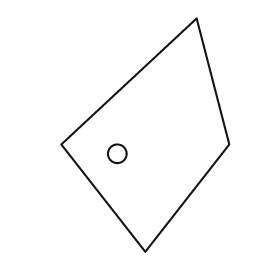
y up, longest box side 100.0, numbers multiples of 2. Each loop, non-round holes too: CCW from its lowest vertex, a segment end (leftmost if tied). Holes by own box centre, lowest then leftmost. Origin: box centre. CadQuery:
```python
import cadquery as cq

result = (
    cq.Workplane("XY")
    .moveTo(0.0, -50.0)
    .lineTo(36.0, -4.0)
    .lineTo(22.0, 50.0)
    .lineTo(-36.0, -4.0)
    .close()
    .moveTo(-12.0, -8.0)
    .circle(4.0)
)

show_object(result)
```